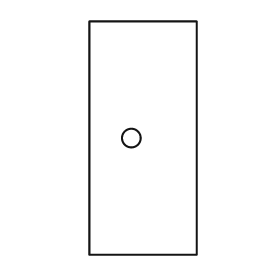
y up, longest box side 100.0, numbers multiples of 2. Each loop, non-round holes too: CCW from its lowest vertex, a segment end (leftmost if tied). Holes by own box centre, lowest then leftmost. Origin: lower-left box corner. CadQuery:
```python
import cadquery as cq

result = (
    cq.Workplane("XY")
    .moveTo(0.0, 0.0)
    .lineTo(46.0, 0.0)
    .lineTo(46.0, 100.0)
    .lineTo(0.0, 100.0)
    .close()
    .moveTo(18.0, 50.0)
    .circle(4.0)
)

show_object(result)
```